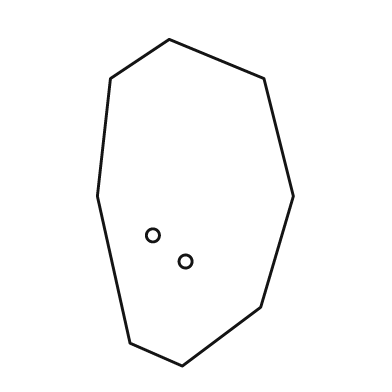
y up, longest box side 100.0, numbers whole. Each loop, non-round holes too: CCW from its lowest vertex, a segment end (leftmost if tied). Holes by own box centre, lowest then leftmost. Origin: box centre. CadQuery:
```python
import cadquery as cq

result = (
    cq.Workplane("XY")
    .moveTo(-4.0, -50.0)
    .lineTo(20.0, -32.0)
    .lineTo(30.0, 2.0)
    .lineTo(21.0, 38.0)
    .lineTo(-8.0, 50.0)
    .lineTo(-26.0, 38.0)
    .lineTo(-30.0, 2.0)
    .lineTo(-20.0, -43.0)
    .close()
    .moveTo(-3.0, -18.0)
    .circle(2.0)
    .moveTo(-13.0, -10.0)
    .circle(2.0)
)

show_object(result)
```